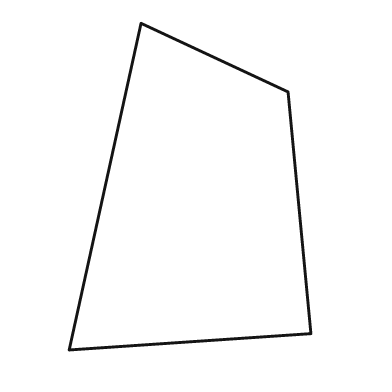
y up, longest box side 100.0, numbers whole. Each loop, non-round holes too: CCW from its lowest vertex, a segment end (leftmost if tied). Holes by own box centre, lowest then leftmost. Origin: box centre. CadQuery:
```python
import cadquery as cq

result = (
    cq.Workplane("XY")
    .moveTo(-37.0, -50.0)
    .lineTo(37.0, -45.0)
    .lineTo(30.0, 29.0)
    .lineTo(-15.0, 50.0)
    .close()
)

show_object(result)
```